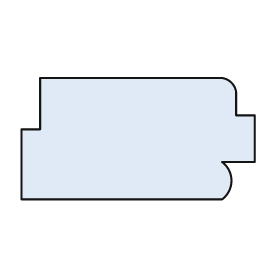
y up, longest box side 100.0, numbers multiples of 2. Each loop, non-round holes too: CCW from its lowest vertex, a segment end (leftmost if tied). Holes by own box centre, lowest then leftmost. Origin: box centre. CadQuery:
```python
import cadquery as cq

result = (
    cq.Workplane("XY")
    .moveTo(-50.0, -26.0)
    .lineTo(36.0, -26.0)
    .threePointArc((40.0, -18.0), (36.0, -10.0))
    .lineTo(50.0, -10.0)
    .lineTo(50.0, 10.0)
    .lineTo(42.0, 10.0)
    .lineTo(42.0, 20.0)
    .threePointArc((40.0, 24.0), (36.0, 26.0))
    .lineTo(-42.0, 26.0)
    .lineTo(-42.0, 4.0)
    .lineTo(-50.0, 4.0)
    .close()
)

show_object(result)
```